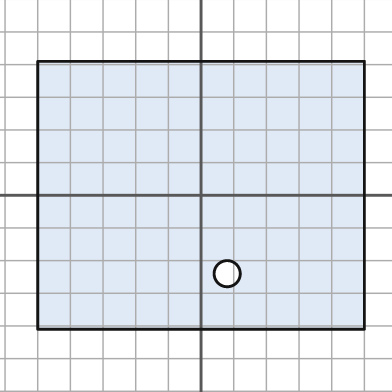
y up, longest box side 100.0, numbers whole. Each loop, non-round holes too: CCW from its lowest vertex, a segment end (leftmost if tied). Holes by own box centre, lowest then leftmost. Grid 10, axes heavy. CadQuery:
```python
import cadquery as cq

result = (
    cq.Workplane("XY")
    .moveTo(-50.0, -41.0)
    .lineTo(50.0, -41.0)
    .lineTo(50.0, 41.0)
    .lineTo(-50.0, 41.0)
    .close()
    .moveTo(8.0, -24.0)
    .circle(4.0)
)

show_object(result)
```